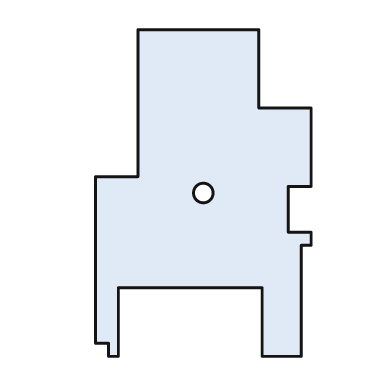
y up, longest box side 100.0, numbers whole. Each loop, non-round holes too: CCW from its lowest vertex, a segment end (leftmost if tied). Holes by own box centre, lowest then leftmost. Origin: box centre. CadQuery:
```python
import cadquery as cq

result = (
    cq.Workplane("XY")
    .moveTo(-29.0, -50.0)
    .lineTo(-26.0, -50.0)
    .lineTo(-26.0, -29.0)
    .lineTo(18.0, -29.0)
    .lineTo(18.0, -50.0)
    .lineTo(30.0, -50.0)
    .lineTo(30.0, -16.0)
    .lineTo(33.0, -16.0)
    .lineTo(33.0, -12.0)
    .lineTo(26.0, -12.0)
    .lineTo(26.0, 2.0)
    .lineTo(33.0, 2.0)
    .lineTo(33.0, 26.0)
    .lineTo(17.0, 26.0)
    .lineTo(17.0, 50.0)
    .lineTo(-20.0, 50.0)
    .lineTo(-20.0, 5.0)
    .lineTo(-33.0, 5.0)
    .lineTo(-33.0, -46.0)
    .lineTo(-29.0, -46.0)
    .close()
    .moveTo(0.0, 0.0)
    .circle(3.0)
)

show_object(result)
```